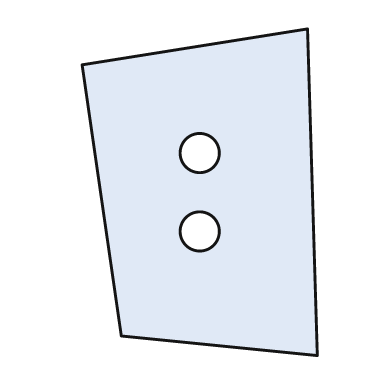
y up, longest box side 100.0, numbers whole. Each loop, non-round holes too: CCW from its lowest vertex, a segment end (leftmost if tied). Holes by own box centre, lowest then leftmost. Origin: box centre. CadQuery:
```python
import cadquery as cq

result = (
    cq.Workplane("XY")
    .moveTo(36.0, -50.0)
    .lineTo(33.0, 50.0)
    .lineTo(-36.0, 39.0)
    .lineTo(-24.0, -44.0)
    .close()
    .moveTo(0.0, -12.0)
    .circle(6.0)
    .moveTo(0.0, 12.0)
    .circle(6.0)
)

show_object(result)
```